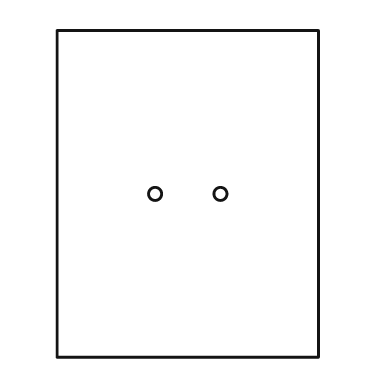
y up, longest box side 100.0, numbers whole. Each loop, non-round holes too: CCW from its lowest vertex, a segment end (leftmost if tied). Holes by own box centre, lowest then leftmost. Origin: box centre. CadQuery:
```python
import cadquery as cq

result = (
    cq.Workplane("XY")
    .moveTo(-40.0, -50.0)
    .lineTo(40.0, -50.0)
    .lineTo(40.0, 50.0)
    .lineTo(-40.0, 50.0)
    .close()
    .moveTo(-10.0, 0.0)
    .circle(2.0)
    .moveTo(10.0, 0.0)
    .circle(2.0)
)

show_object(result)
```